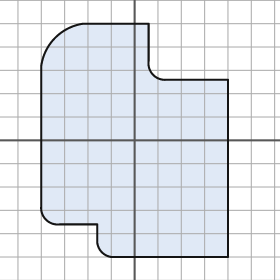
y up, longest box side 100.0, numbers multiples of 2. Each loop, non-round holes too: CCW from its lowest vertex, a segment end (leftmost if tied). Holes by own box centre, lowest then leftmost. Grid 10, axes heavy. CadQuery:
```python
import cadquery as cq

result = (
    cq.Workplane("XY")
    .moveTo(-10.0, -50.0)
    .lineTo(40.0, -50.0)
    .lineTo(40.0, 26.0)
    .lineTo(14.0, 26.0)
    .threePointArc((8.0, 28.0), (6.0, 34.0))
    .lineTo(6.0, 50.0)
    .lineTo(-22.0, 50.0)
    .threePointArc((-34.0, 44.0), (-40.0, 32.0))
    .lineTo(-40.0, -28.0)
    .threePointArc((-38.0, -34.0), (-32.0, -36.0))
    .lineTo(-16.0, -36.0)
    .lineTo(-16.0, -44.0)
    .threePointArc((-14.0, -48.0), (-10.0, -50.0))
    .close()
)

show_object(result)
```